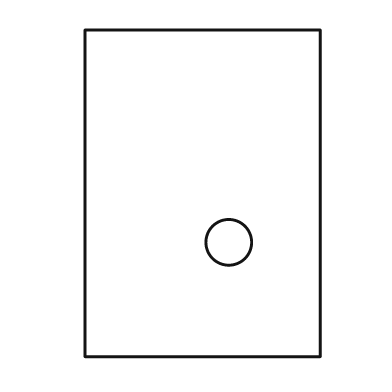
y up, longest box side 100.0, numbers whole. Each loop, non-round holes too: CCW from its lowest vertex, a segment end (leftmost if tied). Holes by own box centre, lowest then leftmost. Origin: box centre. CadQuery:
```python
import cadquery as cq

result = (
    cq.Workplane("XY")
    .moveTo(-36.0, -50.0)
    .lineTo(36.0, -50.0)
    .lineTo(36.0, 50.0)
    .lineTo(-36.0, 50.0)
    .close()
    .moveTo(8.0, -15.0)
    .circle(7.0)
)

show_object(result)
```